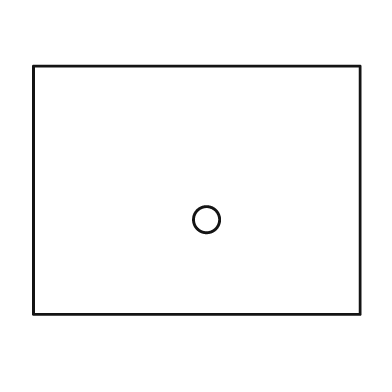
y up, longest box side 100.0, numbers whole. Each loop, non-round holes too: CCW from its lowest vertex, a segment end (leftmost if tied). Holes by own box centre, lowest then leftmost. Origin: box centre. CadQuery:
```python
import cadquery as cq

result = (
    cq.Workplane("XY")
    .moveTo(-50.0, -38.0)
    .lineTo(50.0, -38.0)
    .lineTo(50.0, 38.0)
    .lineTo(-50.0, 38.0)
    .close()
    .moveTo(3.0, -9.0)
    .circle(4.0)
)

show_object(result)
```